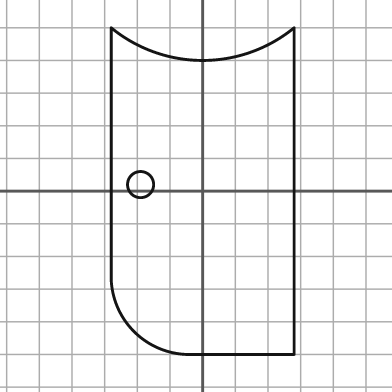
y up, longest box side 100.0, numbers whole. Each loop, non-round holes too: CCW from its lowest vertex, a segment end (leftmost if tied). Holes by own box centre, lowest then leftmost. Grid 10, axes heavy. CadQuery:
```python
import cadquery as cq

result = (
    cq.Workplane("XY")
    .moveTo(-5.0, -50.0)
    .lineTo(28.0, -50.0)
    .lineTo(28.0, 50.0)
    .threePointArc((0.0, 40.0), (-28.0, 50.0))
    .lineTo(-28.0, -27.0)
    .threePointArc((-21.0, -43.0), (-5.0, -50.0))
    .close()
    .moveTo(-19.0, 2.0)
    .circle(4.0)
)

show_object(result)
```